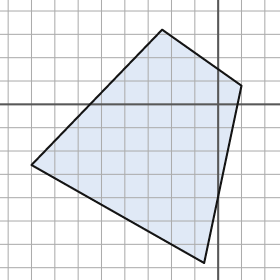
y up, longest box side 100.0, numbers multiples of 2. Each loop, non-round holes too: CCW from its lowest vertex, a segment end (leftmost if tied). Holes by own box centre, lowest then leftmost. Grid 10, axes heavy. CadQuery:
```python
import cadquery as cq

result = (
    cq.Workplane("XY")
    .moveTo(-6.0, -68.0)
    .lineTo(10.0, 8.0)
    .lineTo(-24.0, 32.0)
    .lineTo(-80.0, -26.0)
    .close()
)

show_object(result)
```